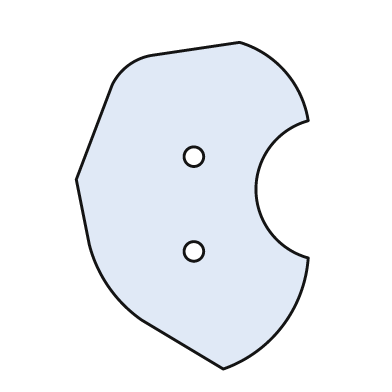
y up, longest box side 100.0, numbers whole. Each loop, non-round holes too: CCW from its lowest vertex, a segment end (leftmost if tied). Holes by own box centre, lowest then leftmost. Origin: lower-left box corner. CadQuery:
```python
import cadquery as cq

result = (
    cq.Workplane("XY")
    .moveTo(45.0, 0.0)
    .threePointArc((63.0, 13.0), (71.0, 34.0))
    .threePointArc((55.0, 55.0), (71.0, 76.0))
    .threePointArc((64.0, 91.0), (50.0, 100.0))
    .lineTo(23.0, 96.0)
    .threePointArc((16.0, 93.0), (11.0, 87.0))
    .lineTo(0.0, 58.0)
    .lineTo(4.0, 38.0)
    .threePointArc((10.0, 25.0), (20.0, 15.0))
    .close()
    .moveTo(36.0, 36.0)
    .circle(3.0)
    .moveTo(36.0, 65.0)
    .circle(3.0)
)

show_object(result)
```